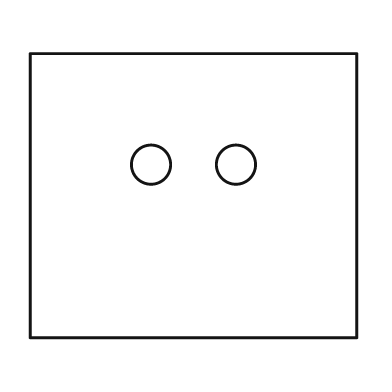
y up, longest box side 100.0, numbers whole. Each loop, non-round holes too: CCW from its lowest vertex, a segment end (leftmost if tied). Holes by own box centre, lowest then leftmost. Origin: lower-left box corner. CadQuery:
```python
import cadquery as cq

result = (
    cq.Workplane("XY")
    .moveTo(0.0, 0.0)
    .lineTo(100.0, 0.0)
    .lineTo(100.0, 87.0)
    .lineTo(0.0, 87.0)
    .close()
    .moveTo(37.0, 53.0)
    .circle(6.0)
    .moveTo(63.0, 53.0)
    .circle(6.0)
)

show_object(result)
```